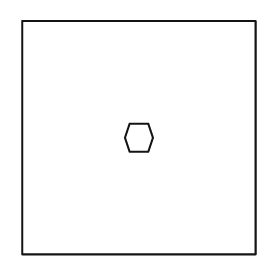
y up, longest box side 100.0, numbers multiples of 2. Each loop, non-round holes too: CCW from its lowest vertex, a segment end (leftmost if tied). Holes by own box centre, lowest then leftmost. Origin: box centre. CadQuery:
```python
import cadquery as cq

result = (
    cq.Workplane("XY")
    .moveTo(-50.0, -50.0)
    .lineTo(50.0, -50.0)
    .lineTo(50.0, 50.0)
    .lineTo(-50.0, 50.0)
    .close()
    .moveTo(-4.0, -6.0)
    .lineTo(4.0, -6.0)
    .lineTo(6.0, 0.0)
    .lineTo(4.0, 6.0)
    .lineTo(-4.0, 6.0)
    .lineTo(-6.0, 0.0)
    .close()
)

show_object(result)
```